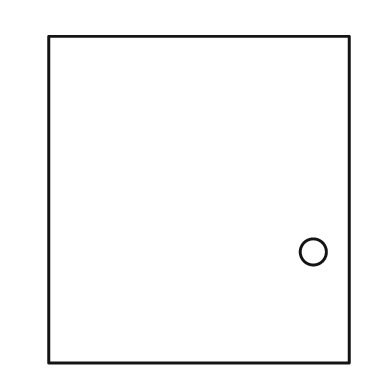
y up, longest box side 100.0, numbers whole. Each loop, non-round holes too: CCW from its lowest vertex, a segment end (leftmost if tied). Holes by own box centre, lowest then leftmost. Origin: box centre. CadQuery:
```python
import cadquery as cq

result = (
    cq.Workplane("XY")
    .moveTo(-46.0, -50.0)
    .lineTo(46.0, -50.0)
    .lineTo(46.0, 50.0)
    .lineTo(-46.0, 50.0)
    .close()
    .moveTo(35.0, -16.0)
    .circle(4.0)
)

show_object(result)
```